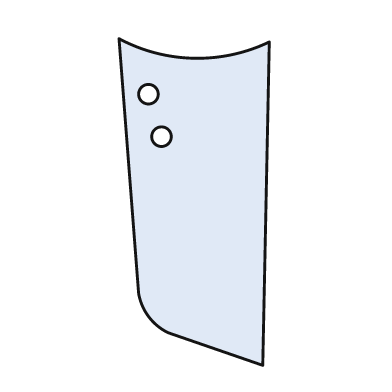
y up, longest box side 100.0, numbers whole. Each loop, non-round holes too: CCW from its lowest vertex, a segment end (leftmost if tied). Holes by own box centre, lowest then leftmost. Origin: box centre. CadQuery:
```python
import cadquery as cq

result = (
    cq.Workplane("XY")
    .moveTo(21.0, -50.0)
    .lineTo(23.0, 49.0)
    .threePointArc((0.0, 44.0), (-23.0, 50.0))
    .lineTo(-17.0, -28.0)
    .threePointArc((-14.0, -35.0), (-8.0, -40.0))
    .close()
    .moveTo(-10.0, 20.0)
    .circle(3.0)
    .moveTo(-14.0, 33.0)
    .circle(3.0)
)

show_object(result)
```